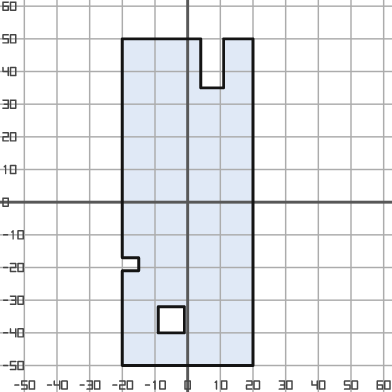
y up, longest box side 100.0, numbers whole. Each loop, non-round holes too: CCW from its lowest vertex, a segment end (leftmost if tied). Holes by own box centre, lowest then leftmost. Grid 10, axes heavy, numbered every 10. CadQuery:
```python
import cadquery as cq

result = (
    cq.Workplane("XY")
    .moveTo(-20.0, -50.0)
    .lineTo(20.0, -50.0)
    .lineTo(20.0, 50.0)
    .lineTo(11.0, 50.0)
    .lineTo(11.0, 35.0)
    .lineTo(4.0, 35.0)
    .lineTo(4.0, 50.0)
    .lineTo(-20.0, 50.0)
    .lineTo(-20.0, -17.0)
    .lineTo(-15.0, -17.0)
    .lineTo(-15.0, -21.0)
    .lineTo(-20.0, -21.0)
    .close()
    .moveTo(-9.0, -40.0)
    .lineTo(-1.0, -40.0)
    .lineTo(-1.0, -32.0)
    .lineTo(-9.0, -32.0)
    .close()
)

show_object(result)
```